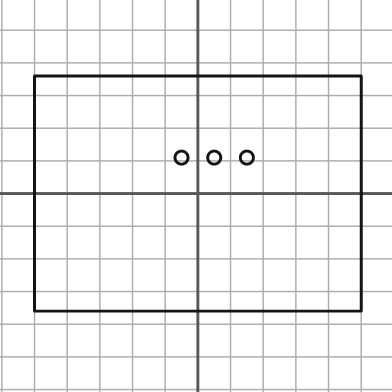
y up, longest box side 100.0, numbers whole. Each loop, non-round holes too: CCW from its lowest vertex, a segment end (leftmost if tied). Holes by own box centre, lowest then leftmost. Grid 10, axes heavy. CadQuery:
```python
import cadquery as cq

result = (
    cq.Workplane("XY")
    .moveTo(-50.0, -36.0)
    .lineTo(50.0, -36.0)
    .lineTo(50.0, 36.0)
    .lineTo(-50.0, 36.0)
    .close()
    .moveTo(-5.0, 11.0)
    .circle(2.0)
    .moveTo(5.0, 11.0)
    .circle(2.0)
    .moveTo(15.0, 11.0)
    .circle(2.0)
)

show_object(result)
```